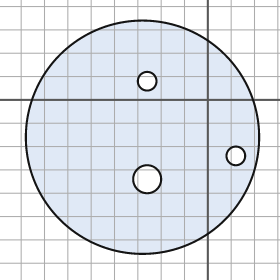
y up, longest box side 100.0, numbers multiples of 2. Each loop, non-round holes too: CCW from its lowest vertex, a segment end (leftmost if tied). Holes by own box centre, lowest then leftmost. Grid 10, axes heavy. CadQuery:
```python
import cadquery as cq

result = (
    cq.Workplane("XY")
    .moveTo(-28.0, -16.0)
    .circle(50.0)
    .moveTo(-26.0, -34.0)
    .circle(6.0)
    .moveTo(12.0, -24.0)
    .circle(4.0)
    .moveTo(-26.0, 8.0)
    .circle(4.0)
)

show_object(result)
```